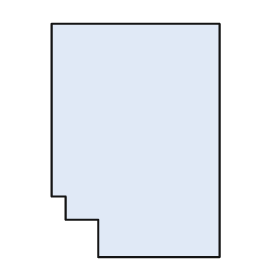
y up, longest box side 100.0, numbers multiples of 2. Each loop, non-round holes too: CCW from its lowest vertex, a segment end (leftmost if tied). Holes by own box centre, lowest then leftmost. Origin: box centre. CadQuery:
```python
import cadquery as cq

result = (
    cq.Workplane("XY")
    .moveTo(-16.0, -50.0)
    .lineTo(36.0, -50.0)
    .lineTo(36.0, 50.0)
    .lineTo(-36.0, 50.0)
    .lineTo(-36.0, -24.0)
    .lineTo(-30.0, -24.0)
    .lineTo(-30.0, -34.0)
    .lineTo(-16.0, -34.0)
    .close()
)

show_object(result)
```